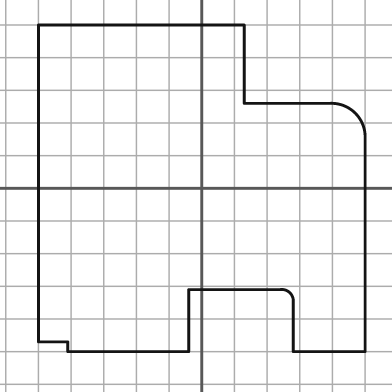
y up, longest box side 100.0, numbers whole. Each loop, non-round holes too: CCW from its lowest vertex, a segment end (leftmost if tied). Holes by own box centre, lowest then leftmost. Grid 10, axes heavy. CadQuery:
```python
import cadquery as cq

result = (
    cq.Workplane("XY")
    .moveTo(-41.0, -50.0)
    .lineTo(-4.0, -50.0)
    .lineTo(-4.0, -31.0)
    .lineTo(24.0, -31.0)
    .threePointArc((27.0, -32.0), (28.0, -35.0))
    .lineTo(28.0, -50.0)
    .lineTo(50.0, -50.0)
    .lineTo(50.0, 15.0)
    .threePointArc((47.0, 23.0), (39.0, 26.0))
    .lineTo(13.0, 26.0)
    .lineTo(13.0, 50.0)
    .lineTo(-50.0, 50.0)
    .lineTo(-50.0, -47.0)
    .lineTo(-41.0, -47.0)
    .close()
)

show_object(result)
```